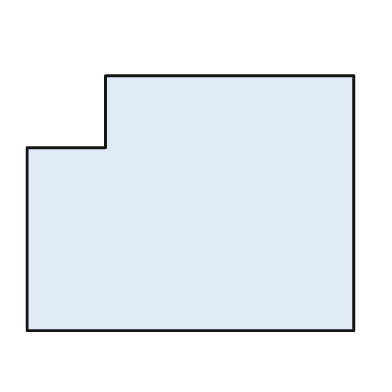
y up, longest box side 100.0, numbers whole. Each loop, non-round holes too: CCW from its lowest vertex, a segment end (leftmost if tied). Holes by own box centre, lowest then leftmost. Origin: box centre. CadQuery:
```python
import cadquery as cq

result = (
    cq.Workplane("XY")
    .moveTo(-50.0, -39.0)
    .lineTo(50.0, -39.0)
    .lineTo(50.0, 39.0)
    .lineTo(-26.0, 39.0)
    .lineTo(-26.0, 17.0)
    .lineTo(-50.0, 17.0)
    .close()
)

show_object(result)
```